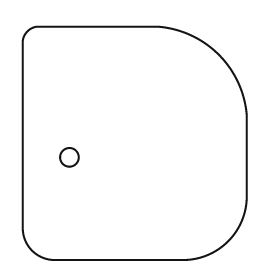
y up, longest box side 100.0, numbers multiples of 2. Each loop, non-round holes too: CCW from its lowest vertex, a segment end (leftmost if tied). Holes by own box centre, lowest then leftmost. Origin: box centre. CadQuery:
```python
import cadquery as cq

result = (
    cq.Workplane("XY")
    .moveTo(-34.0, -50.0)
    .lineTo(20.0, -50.0)
    .threePointArc((40.0, -42.0), (48.0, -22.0))
    .lineTo(48.0, 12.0)
    .threePointArc((36.0, 38.0), (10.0, 50.0))
    .lineTo(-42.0, 50.0)
    .threePointArc((-46.0, 48.0), (-48.0, 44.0))
    .lineTo(-48.0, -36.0)
    .threePointArc((-44.0, -46.0), (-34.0, -50.0))
    .close()
    .moveTo(-28.0, -6.0)
    .circle(4.0)
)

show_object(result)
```